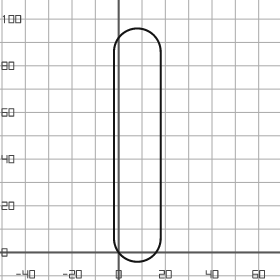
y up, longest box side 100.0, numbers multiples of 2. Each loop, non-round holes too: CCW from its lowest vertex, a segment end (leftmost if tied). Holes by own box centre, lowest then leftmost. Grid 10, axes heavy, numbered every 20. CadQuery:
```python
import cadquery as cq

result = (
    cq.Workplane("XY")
    .moveTo(-2.0, 6.0)
    .threePointArc((8.0, -4.0), (18.0, 6.0))
    .lineTo(18.0, 86.0)
    .threePointArc((8.0, 96.0), (-2.0, 86.0))
    .close()
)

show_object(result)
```